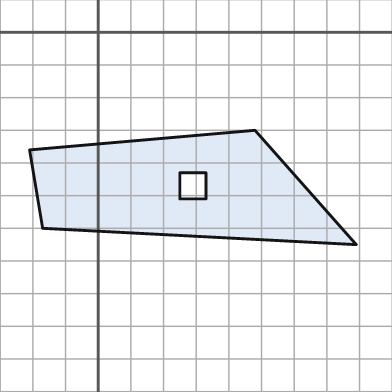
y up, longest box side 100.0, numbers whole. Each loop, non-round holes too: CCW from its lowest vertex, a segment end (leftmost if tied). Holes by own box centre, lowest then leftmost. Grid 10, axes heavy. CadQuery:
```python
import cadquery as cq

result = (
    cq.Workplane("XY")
    .moveTo(79.0, -65.0)
    .lineTo(48.0, -30.0)
    .lineTo(-21.0, -36.0)
    .lineTo(-17.0, -60.0)
    .close()
    .moveTo(25.0, -51.0)
    .lineTo(33.0, -51.0)
    .lineTo(33.0, -43.0)
    .lineTo(25.0, -43.0)
    .close()
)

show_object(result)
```